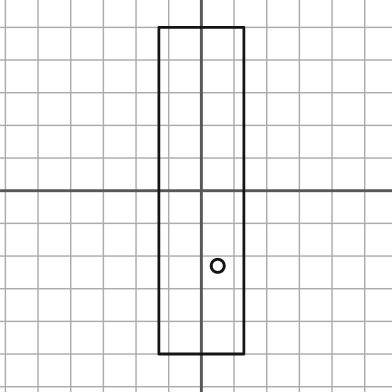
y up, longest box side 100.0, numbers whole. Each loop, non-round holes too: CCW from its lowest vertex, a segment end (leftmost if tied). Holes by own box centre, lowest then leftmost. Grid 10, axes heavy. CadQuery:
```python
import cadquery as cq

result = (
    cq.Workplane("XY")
    .moveTo(-13.0, -50.0)
    .lineTo(13.0, -50.0)
    .lineTo(13.0, 50.0)
    .lineTo(-13.0, 50.0)
    .close()
    .moveTo(5.0, -23.0)
    .circle(2.0)
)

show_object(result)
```